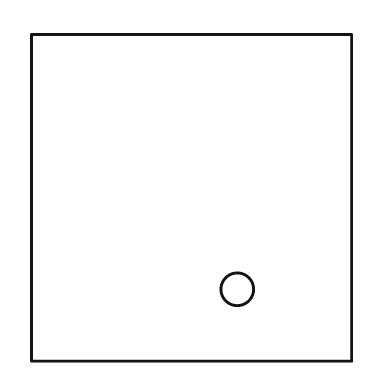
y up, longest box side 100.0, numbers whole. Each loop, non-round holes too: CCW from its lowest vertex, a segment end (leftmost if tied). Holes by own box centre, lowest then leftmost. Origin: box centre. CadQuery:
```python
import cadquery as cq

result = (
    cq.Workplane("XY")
    .moveTo(-49.0, -50.0)
    .lineTo(49.0, -50.0)
    .lineTo(49.0, 50.0)
    .lineTo(-49.0, 50.0)
    .close()
    .moveTo(14.0, -28.0)
    .circle(5.0)
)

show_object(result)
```